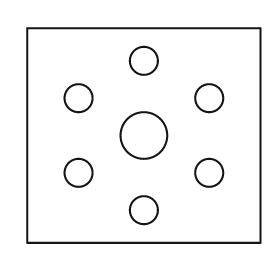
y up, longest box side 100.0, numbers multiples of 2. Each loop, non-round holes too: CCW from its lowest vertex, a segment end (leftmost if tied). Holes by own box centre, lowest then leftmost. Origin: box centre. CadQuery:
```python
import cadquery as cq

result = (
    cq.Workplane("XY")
    .moveTo(-50.0, -46.0)
    .lineTo(50.0, -46.0)
    .lineTo(50.0, 46.0)
    .lineTo(-50.0, 46.0)
    .close()
    .moveTo(0.0, -32.0)
    .circle(6.0)
    .moveTo(-28.0, -16.0)
    .circle(6.0)
    .moveTo(28.0, -16.0)
    .circle(6.0)
    .moveTo(0.0, 0.0)
    .circle(10.0)
    .moveTo(-28.0, 16.0)
    .circle(6.0)
    .moveTo(28.0, 16.0)
    .circle(6.0)
    .moveTo(0.0, 32.0)
    .circle(6.0)
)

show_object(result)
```